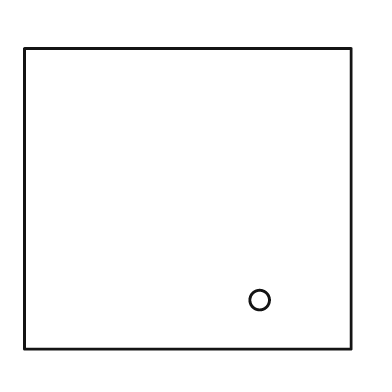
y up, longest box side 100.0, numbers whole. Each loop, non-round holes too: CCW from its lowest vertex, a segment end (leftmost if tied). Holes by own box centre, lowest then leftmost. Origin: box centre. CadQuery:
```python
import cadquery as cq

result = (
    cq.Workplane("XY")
    .moveTo(-50.0, -46.0)
    .lineTo(50.0, -46.0)
    .lineTo(50.0, 46.0)
    .lineTo(-50.0, 46.0)
    .close()
    .moveTo(22.0, -31.0)
    .circle(3.0)
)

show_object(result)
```